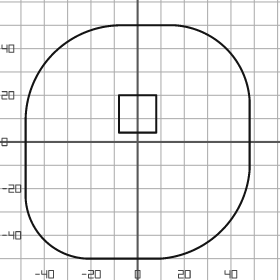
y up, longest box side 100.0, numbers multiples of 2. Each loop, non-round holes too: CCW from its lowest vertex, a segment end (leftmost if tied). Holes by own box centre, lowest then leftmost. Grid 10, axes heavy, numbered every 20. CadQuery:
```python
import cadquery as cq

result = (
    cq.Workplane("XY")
    .moveTo(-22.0, -50.0)
    .lineTo(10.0, -50.0)
    .threePointArc((36.0, -38.0), (48.0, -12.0))
    .lineTo(48.0, 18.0)
    .threePointArc((38.0, 40.0), (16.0, 50.0))
    .lineTo(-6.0, 50.0)
    .threePointArc((-36.0, 38.0), (-48.0, 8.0))
    .lineTo(-48.0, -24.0)
    .threePointArc((-40.0, -42.0), (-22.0, -50.0))
    .close()
    .moveTo(-8.0, 4.0)
    .lineTo(8.0, 4.0)
    .lineTo(8.0, 20.0)
    .lineTo(-8.0, 20.0)
    .close()
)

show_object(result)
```